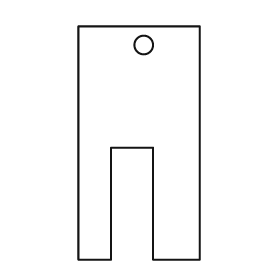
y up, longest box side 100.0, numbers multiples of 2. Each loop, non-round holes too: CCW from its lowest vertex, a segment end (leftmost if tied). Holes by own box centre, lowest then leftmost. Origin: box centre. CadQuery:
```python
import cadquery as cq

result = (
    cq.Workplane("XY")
    .moveTo(-26.0, -50.0)
    .lineTo(-12.0, -50.0)
    .lineTo(-12.0, -2.0)
    .lineTo(6.0, -2.0)
    .lineTo(6.0, -50.0)
    .lineTo(26.0, -50.0)
    .lineTo(26.0, 50.0)
    .lineTo(-26.0, 50.0)
    .close()
    .moveTo(2.0, 42.0)
    .circle(4.0)
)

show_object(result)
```